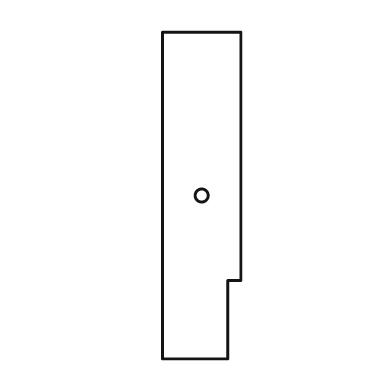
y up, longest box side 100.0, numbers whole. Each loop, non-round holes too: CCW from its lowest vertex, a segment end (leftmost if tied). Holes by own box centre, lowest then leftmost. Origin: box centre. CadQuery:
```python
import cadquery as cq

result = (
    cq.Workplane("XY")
    .moveTo(-12.0, -50.0)
    .lineTo(8.0, -50.0)
    .lineTo(8.0, -26.0)
    .lineTo(12.0, -26.0)
    .lineTo(12.0, 50.0)
    .lineTo(-12.0, 50.0)
    .close()
    .moveTo(0.0, 0.0)
    .circle(2.0)
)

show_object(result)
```